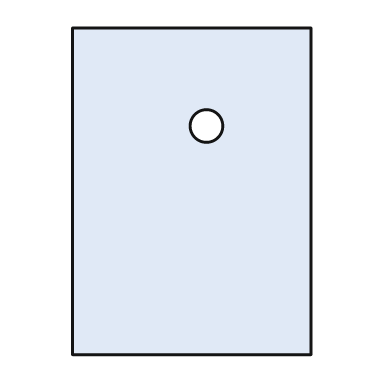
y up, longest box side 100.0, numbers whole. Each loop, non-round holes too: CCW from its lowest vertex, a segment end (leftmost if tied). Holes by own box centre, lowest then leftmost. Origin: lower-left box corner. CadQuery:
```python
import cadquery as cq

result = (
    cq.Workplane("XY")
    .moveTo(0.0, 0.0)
    .lineTo(73.0, 0.0)
    .lineTo(73.0, 100.0)
    .lineTo(0.0, 100.0)
    .close()
    .moveTo(41.0, 70.0)
    .circle(5.0)
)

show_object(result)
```